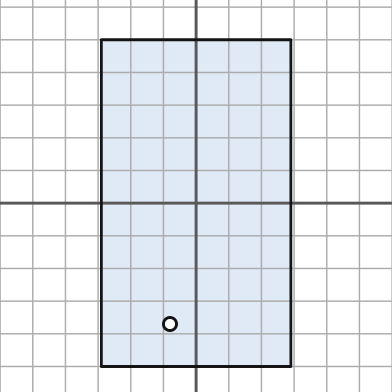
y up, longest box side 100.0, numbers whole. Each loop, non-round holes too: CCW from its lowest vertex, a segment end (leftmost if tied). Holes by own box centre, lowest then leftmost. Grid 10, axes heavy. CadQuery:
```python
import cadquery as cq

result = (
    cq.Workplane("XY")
    .moveTo(-29.0, -50.0)
    .lineTo(29.0, -50.0)
    .lineTo(29.0, 50.0)
    .lineTo(-29.0, 50.0)
    .close()
    .moveTo(-8.0, -37.0)
    .circle(2.0)
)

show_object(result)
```